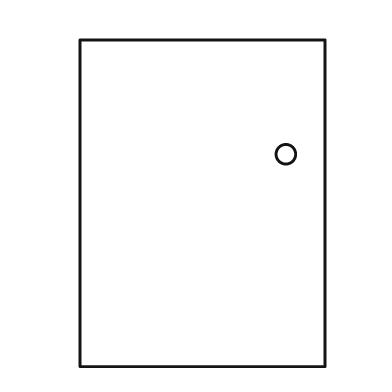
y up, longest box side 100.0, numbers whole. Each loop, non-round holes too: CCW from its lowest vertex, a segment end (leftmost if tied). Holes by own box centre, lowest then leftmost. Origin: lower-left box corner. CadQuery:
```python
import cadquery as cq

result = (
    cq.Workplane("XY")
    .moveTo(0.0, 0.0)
    .lineTo(75.0, 0.0)
    .lineTo(75.0, 100.0)
    .lineTo(0.0, 100.0)
    .close()
    .moveTo(63.0, 65.0)
    .circle(3.0)
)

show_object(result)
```